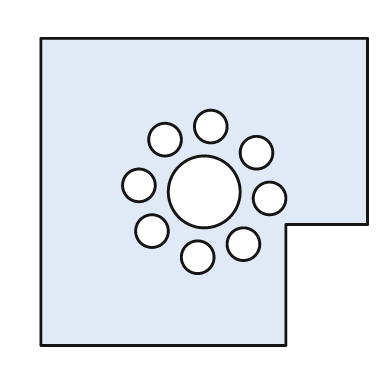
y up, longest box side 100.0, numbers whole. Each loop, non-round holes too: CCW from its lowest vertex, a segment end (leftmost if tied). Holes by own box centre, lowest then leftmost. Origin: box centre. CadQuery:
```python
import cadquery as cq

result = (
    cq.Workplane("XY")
    .moveTo(-50.0, -47.0)
    .lineTo(25.0, -47.0)
    .lineTo(25.0, -10.0)
    .lineTo(50.0, -10.0)
    .lineTo(50.0, 47.0)
    .lineTo(-50.0, 47.0)
    .close()
    .moveTo(-2.0, -20.0)
    .circle(5.0)
    .moveTo(12.0, -16.0)
    .circle(5.0)
    .moveTo(-16.0, -12.0)
    .circle(5.0)
    .moveTo(20.0, -2.0)
    .circle(5.0)
    .moveTo(0.0, 0.0)
    .circle(11.0)
    .moveTo(-20.0, 2.0)
    .circle(5.0)
    .moveTo(16.0, 12.0)
    .circle(5.0)
    .moveTo(-12.0, 16.0)
    .circle(5.0)
    .moveTo(2.0, 20.0)
    .circle(5.0)
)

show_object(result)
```